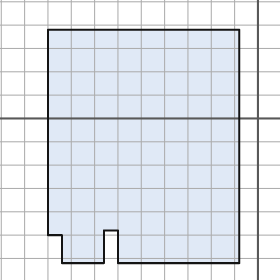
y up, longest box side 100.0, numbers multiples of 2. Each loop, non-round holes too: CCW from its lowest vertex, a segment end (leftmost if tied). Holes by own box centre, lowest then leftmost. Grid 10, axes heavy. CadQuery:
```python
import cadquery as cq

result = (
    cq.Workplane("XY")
    .moveTo(-84.0, -62.0)
    .lineTo(-66.0, -62.0)
    .lineTo(-66.0, -48.0)
    .lineTo(-60.0, -48.0)
    .lineTo(-60.0, -62.0)
    .lineTo(-8.0, -62.0)
    .lineTo(-8.0, 38.0)
    .lineTo(-90.0, 38.0)
    .lineTo(-90.0, -50.0)
    .lineTo(-84.0, -50.0)
    .close()
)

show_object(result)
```